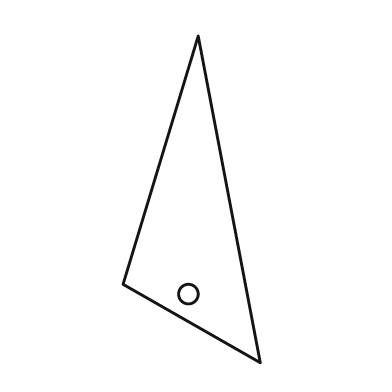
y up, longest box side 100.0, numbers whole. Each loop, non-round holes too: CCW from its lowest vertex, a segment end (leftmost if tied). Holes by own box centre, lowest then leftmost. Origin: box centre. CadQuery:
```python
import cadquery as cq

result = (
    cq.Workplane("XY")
    .moveTo(21.0, -50.0)
    .lineTo(2.0, 50.0)
    .lineTo(-21.0, -26.0)
    .close()
    .moveTo(-1.0, -29.0)
    .circle(3.0)
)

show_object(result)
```